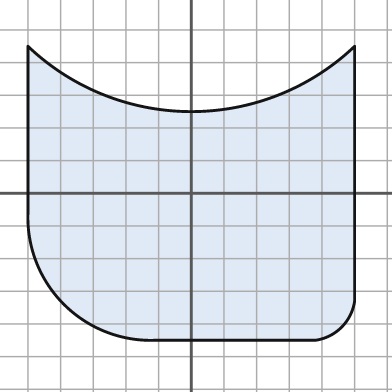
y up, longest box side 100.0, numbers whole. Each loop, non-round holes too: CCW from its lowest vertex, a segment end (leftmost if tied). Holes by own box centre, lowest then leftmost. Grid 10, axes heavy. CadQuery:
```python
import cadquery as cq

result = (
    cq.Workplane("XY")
    .moveTo(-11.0, -45.0)
    .lineTo(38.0, -45.0)
    .threePointArc((46.0, -41.0), (50.0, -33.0))
    .lineTo(50.0, 45.0)
    .threePointArc((0.0, 25.0), (-50.0, 45.0))
    .lineTo(-50.0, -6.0)
    .threePointArc((-39.0, -34.0), (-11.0, -45.0))
    .close()
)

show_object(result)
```